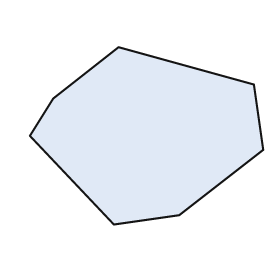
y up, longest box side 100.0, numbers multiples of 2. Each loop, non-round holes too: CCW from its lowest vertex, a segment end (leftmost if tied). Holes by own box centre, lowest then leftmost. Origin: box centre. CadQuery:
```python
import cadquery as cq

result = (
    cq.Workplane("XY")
    .moveTo(-14.0, -38.0)
    .lineTo(14.0, -34.0)
    .lineTo(50.0, -6.0)
    .lineTo(46.0, 22.0)
    .lineTo(-12.0, 38.0)
    .lineTo(-40.0, 16.0)
    .lineTo(-50.0, 0.0)
    .close()
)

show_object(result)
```